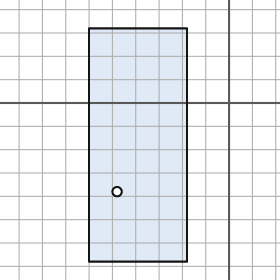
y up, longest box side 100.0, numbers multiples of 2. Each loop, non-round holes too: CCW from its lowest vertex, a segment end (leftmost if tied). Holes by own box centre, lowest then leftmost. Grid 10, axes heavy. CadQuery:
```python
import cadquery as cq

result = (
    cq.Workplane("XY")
    .moveTo(-60.0, -68.0)
    .lineTo(-18.0, -68.0)
    .lineTo(-18.0, 32.0)
    .lineTo(-60.0, 32.0)
    .close()
    .moveTo(-48.0, -38.0)
    .circle(2.0)
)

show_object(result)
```